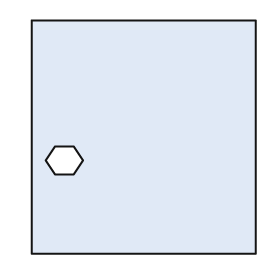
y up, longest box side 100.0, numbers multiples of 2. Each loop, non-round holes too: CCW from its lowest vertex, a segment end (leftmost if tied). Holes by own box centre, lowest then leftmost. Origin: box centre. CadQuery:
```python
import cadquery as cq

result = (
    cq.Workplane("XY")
    .moveTo(-48.0, -50.0)
    .lineTo(48.0, -50.0)
    .lineTo(48.0, 50.0)
    .lineTo(-48.0, 50.0)
    .close()
    .moveTo(-38.0, -16.0)
    .lineTo(-30.0, -16.0)
    .lineTo(-26.0, -10.0)
    .lineTo(-30.0, -4.0)
    .lineTo(-38.0, -4.0)
    .lineTo(-42.0, -10.0)
    .close()
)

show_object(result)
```